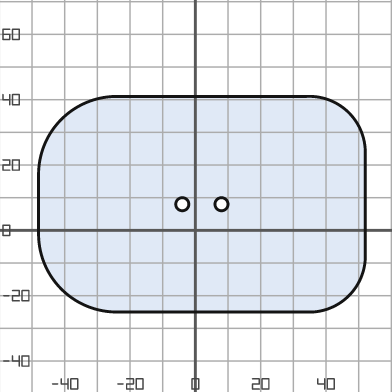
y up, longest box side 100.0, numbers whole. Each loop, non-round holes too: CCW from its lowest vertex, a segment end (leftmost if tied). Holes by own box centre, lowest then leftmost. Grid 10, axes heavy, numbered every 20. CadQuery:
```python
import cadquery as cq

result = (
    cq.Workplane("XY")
    .moveTo(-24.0, -25.0)
    .lineTo(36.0, -25.0)
    .threePointArc((47.0, -20.0), (52.0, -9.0))
    .lineTo(52.0, 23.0)
    .threePointArc((47.0, 36.0), (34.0, 41.0))
    .lineTo(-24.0, 41.0)
    .threePointArc((-41.0, 34.0), (-48.0, 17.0))
    .lineTo(-48.0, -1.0)
    .threePointArc((-41.0, -18.0), (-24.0, -25.0))
    .close()
    .moveTo(-4.0, 8.0)
    .circle(2.0)
    .moveTo(8.0, 8.0)
    .circle(2.0)
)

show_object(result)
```